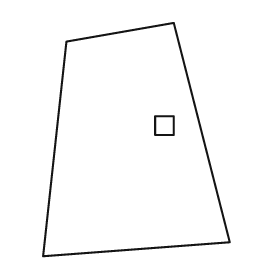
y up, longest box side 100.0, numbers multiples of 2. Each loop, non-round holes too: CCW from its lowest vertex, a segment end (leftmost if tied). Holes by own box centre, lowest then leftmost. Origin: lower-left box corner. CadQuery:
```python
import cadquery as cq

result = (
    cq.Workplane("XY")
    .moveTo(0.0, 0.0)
    .lineTo(80.0, 6.0)
    .lineTo(56.0, 100.0)
    .lineTo(10.0, 92.0)
    .close()
    .moveTo(48.0, 52.0)
    .lineTo(56.0, 52.0)
    .lineTo(56.0, 60.0)
    .lineTo(48.0, 60.0)
    .close()
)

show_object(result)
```